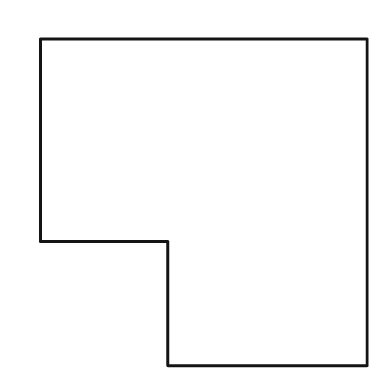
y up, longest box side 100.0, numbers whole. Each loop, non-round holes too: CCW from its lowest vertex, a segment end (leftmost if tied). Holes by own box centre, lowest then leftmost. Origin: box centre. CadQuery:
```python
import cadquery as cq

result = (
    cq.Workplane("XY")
    .moveTo(-11.0, -50.0)
    .lineTo(50.0, -50.0)
    .lineTo(50.0, 50.0)
    .lineTo(-50.0, 50.0)
    .lineTo(-50.0, -12.0)
    .lineTo(-11.0, -12.0)
    .close()
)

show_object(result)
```